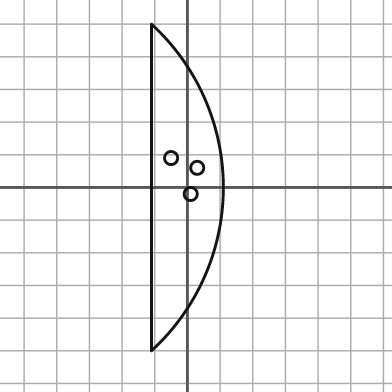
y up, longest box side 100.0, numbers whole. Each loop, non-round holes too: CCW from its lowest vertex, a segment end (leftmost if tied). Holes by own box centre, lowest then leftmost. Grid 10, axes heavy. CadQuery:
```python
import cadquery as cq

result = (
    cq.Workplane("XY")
    .moveTo(-11.0, -50.0)
    .threePointArc((11.0, 0.0), (-11.0, 50.0))
    .close()
    .moveTo(1.0, -2.0)
    .circle(2.0)
    .moveTo(3.0, 6.0)
    .circle(2.0)
    .moveTo(-5.0, 9.0)
    .circle(2.0)
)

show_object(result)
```